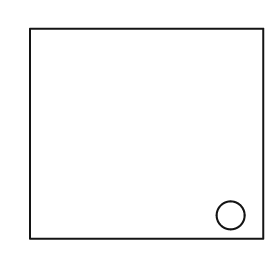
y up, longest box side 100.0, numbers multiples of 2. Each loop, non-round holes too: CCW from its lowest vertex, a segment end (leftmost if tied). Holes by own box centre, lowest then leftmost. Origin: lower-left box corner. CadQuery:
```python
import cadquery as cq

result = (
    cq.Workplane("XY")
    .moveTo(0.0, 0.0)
    .lineTo(100.0, 0.0)
    .lineTo(100.0, 90.0)
    .lineTo(0.0, 90.0)
    .close()
    .moveTo(86.0, 10.0)
    .circle(6.0)
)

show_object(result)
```